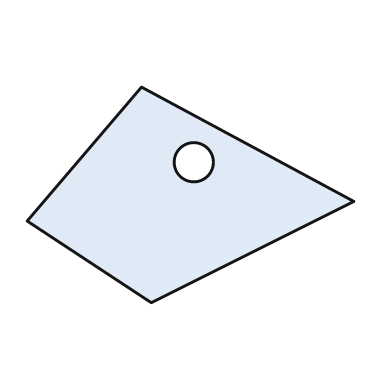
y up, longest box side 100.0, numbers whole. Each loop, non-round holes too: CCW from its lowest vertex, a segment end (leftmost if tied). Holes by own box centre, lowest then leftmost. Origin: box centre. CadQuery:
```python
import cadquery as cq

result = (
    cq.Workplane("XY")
    .moveTo(-12.0, -33.0)
    .lineTo(50.0, -2.0)
    .lineTo(-15.0, 33.0)
    .lineTo(-50.0, -8.0)
    .close()
    .moveTo(1.0, 10.0)
    .circle(6.0)
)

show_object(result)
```